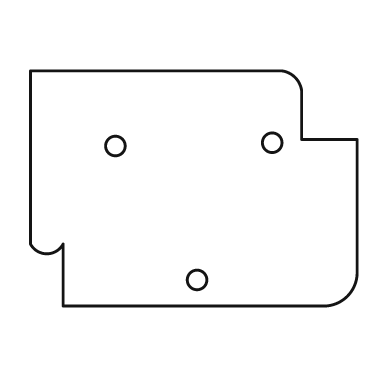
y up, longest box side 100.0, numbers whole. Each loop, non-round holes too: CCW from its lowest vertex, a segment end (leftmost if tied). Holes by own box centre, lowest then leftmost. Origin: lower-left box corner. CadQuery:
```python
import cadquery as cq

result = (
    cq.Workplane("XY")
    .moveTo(10.0, 0.0)
    .lineTo(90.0, 0.0)
    .threePointArc((97.0, 3.0), (100.0, 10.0))
    .lineTo(100.0, 51.0)
    .lineTo(83.0, 51.0)
    .lineTo(83.0, 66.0)
    .threePointArc((81.0, 70.0), (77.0, 72.0))
    .lineTo(0.0, 72.0)
    .lineTo(0.0, 19.0)
    .threePointArc((5.0, 16.0), (10.0, 19.0))
    .close()
    .moveTo(51.0, 8.0)
    .circle(3.0)
    .moveTo(26.0, 49.0)
    .circle(3.0)
    .moveTo(74.0, 50.0)
    .circle(3.0)
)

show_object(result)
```